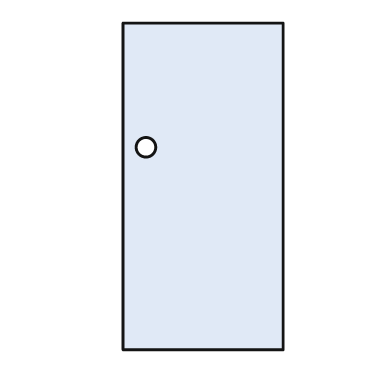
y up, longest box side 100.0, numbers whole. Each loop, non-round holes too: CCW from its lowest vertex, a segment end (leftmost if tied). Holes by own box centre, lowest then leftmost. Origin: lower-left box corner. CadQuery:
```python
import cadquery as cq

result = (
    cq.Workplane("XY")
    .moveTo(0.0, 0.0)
    .lineTo(49.0, 0.0)
    .lineTo(49.0, 100.0)
    .lineTo(0.0, 100.0)
    .close()
    .moveTo(7.0, 62.0)
    .circle(3.0)
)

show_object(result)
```